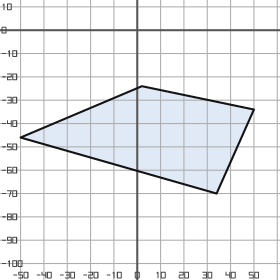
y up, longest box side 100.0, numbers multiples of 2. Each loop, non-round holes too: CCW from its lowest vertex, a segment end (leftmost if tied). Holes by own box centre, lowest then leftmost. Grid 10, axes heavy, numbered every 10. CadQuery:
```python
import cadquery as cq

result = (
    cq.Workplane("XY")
    .moveTo(34.0, -70.0)
    .lineTo(50.0, -34.0)
    .lineTo(2.0, -24.0)
    .lineTo(-50.0, -46.0)
    .close()
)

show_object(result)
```